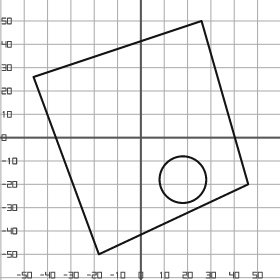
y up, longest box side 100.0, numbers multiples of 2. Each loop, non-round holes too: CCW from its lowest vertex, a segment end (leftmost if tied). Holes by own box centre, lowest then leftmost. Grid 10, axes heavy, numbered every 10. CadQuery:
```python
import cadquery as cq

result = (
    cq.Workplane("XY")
    .moveTo(-18.0, -50.0)
    .lineTo(46.0, -20.0)
    .lineTo(26.0, 50.0)
    .lineTo(-46.0, 26.0)
    .close()
    .moveTo(18.0, -18.0)
    .circle(10.0)
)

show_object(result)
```